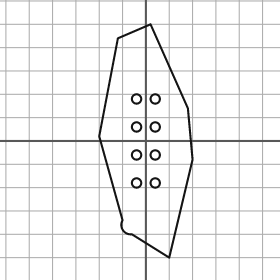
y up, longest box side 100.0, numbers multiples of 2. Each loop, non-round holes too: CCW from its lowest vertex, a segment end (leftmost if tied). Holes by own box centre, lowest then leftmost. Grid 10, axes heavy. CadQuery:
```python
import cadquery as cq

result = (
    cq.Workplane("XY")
    .moveTo(10.0, -50.0)
    .lineTo(20.0, -8.0)
    .lineTo(18.0, 14.0)
    .lineTo(2.0, 50.0)
    .lineTo(-12.0, 44.0)
    .lineTo(-20.0, 2.0)
    .lineTo(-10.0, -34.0)
    .threePointArc((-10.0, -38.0), (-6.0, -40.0))
    .close()
    .moveTo(-4.0, -18.0)
    .circle(2.0)
    .moveTo(4.0, -18.0)
    .circle(2.0)
    .moveTo(-4.0, -6.0)
    .circle(2.0)
    .moveTo(4.0, -6.0)
    .circle(2.0)
    .moveTo(-4.0, 6.0)
    .circle(2.0)
    .moveTo(4.0, 6.0)
    .circle(2.0)
    .moveTo(-4.0, 18.0)
    .circle(2.0)
    .moveTo(4.0, 18.0)
    .circle(2.0)
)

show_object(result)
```